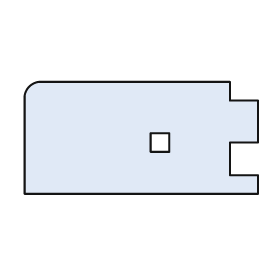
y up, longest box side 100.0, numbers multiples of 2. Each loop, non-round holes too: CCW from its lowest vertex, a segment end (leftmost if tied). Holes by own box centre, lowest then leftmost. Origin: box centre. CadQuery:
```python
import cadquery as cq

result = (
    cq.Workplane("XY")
    .moveTo(-50.0, -24.0)
    .lineTo(50.0, -24.0)
    .lineTo(50.0, -16.0)
    .lineTo(38.0, -16.0)
    .lineTo(38.0, -2.0)
    .lineTo(50.0, -2.0)
    .lineTo(50.0, 16.0)
    .lineTo(38.0, 16.0)
    .lineTo(38.0, 24.0)
    .lineTo(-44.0, 24.0)
    .threePointArc((-48.0, 22.0), (-50.0, 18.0))
    .close()
    .moveTo(4.0, -6.0)
    .lineTo(12.0, -6.0)
    .lineTo(12.0, 2.0)
    .lineTo(4.0, 2.0)
    .close()
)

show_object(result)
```